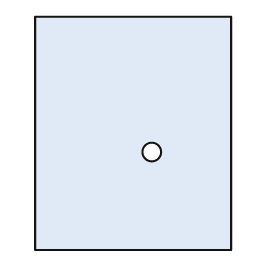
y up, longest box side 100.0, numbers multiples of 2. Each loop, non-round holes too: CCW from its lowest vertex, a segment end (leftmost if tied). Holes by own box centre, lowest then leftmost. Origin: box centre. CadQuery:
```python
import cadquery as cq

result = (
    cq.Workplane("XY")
    .moveTo(-42.0, -50.0)
    .lineTo(42.0, -50.0)
    .lineTo(42.0, 50.0)
    .lineTo(-42.0, 50.0)
    .close()
    .moveTo(8.0, -8.0)
    .circle(4.0)
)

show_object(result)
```